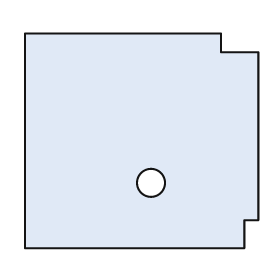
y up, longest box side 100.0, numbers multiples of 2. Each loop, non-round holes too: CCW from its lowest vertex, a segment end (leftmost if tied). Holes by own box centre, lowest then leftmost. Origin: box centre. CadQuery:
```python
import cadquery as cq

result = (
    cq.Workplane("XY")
    .moveTo(-50.0, -46.0)
    .lineTo(44.0, -46.0)
    .lineTo(44.0, -34.0)
    .lineTo(50.0, -34.0)
    .lineTo(50.0, 38.0)
    .lineTo(34.0, 38.0)
    .lineTo(34.0, 46.0)
    .lineTo(-50.0, 46.0)
    .close()
    .moveTo(4.0, -18.0)
    .circle(6.0)
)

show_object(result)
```